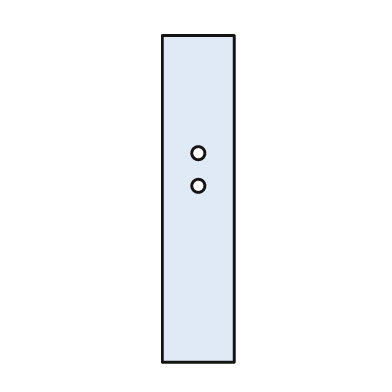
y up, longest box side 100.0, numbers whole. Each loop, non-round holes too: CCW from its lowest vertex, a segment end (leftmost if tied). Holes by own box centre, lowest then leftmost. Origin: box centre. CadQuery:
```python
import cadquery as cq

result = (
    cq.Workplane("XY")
    .moveTo(-11.0, -50.0)
    .lineTo(11.0, -50.0)
    .lineTo(11.0, 50.0)
    .lineTo(-11.0, 50.0)
    .close()
    .moveTo(0.0, 4.0)
    .circle(2.0)
    .moveTo(0.0, 14.0)
    .circle(2.0)
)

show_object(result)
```